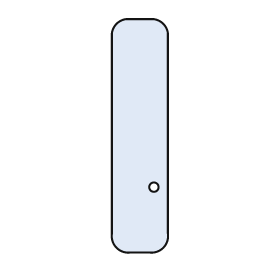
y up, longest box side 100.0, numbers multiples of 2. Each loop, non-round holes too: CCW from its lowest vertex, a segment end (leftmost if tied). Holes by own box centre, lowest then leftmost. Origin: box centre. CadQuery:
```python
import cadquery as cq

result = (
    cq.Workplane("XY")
    .moveTo(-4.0, -50.0)
    .lineTo(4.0, -50.0)
    .threePointArc((10.0, -48.0), (12.0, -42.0))
    .lineTo(12.0, 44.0)
    .threePointArc((10.0, 48.0), (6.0, 50.0))
    .lineTo(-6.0, 50.0)
    .threePointArc((-10.0, 48.0), (-12.0, 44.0))
    .lineTo(-12.0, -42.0)
    .threePointArc((-10.0, -48.0), (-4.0, -50.0))
    .close()
    .moveTo(6.0, -22.0)
    .circle(2.0)
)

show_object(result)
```